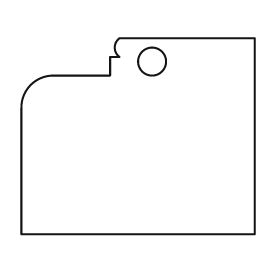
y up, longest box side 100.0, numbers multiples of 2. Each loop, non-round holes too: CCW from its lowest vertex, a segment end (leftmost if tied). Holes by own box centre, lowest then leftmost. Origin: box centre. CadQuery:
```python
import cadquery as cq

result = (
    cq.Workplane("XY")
    .moveTo(-50.0, -42.0)
    .lineTo(50.0, -42.0)
    .lineTo(50.0, 42.0)
    .lineTo(-8.0, 42.0)
    .threePointArc((-10.0, 38.0), (-8.0, 34.0))
    .lineTo(-12.0, 34.0)
    .lineTo(-12.0, 26.0)
    .lineTo(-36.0, 26.0)
    .threePointArc((-46.0, 22.0), (-50.0, 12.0))
    .close()
    .moveTo(6.0, 32.0)
    .circle(6.0)
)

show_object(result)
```